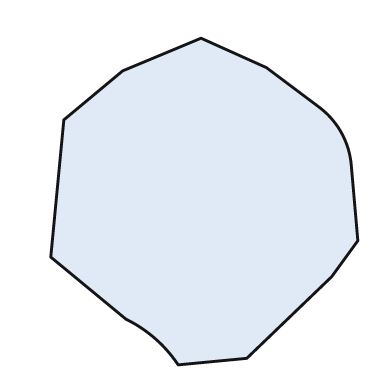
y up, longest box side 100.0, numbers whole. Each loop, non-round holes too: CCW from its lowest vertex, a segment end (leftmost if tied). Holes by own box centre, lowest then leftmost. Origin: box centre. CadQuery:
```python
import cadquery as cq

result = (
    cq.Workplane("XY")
    .moveTo(-8.0, -50.0)
    .lineTo(13.0, -48.0)
    .lineTo(39.0, -23.0)
    .lineTo(47.0, -12.0)
    .lineTo(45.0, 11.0)
    .threePointArc((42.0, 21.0), (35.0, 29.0))
    .lineTo(19.0, 41.0)
    .lineTo(-1.0, 50.0)
    .lineTo(-25.0, 40.0)
    .lineTo(-43.0, 25.0)
    .lineTo(-47.0, -17.0)
    .lineTo(-24.0, -36.0)
    .threePointArc((-15.0, -42.0), (-8.0, -50.0))
    .close()
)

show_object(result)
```